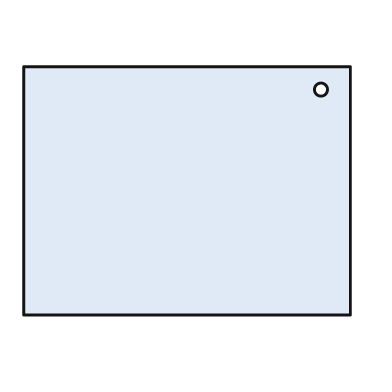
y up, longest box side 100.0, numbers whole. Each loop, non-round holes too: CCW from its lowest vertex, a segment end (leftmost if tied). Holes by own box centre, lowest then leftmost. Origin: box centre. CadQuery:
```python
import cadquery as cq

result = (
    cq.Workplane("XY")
    .moveTo(-50.0, -38.0)
    .lineTo(50.0, -38.0)
    .lineTo(50.0, 38.0)
    .lineTo(-50.0, 38.0)
    .close()
    .moveTo(41.0, 31.0)
    .circle(2.0)
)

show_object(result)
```